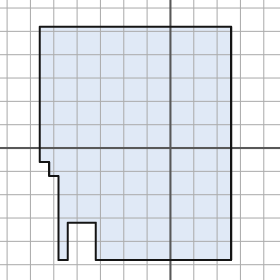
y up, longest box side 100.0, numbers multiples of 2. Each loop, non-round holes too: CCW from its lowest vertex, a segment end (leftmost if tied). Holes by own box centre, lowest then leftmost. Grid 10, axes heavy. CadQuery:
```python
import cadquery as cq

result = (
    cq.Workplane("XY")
    .moveTo(-48.0, -48.0)
    .lineTo(-44.0, -48.0)
    .lineTo(-44.0, -32.0)
    .lineTo(-32.0, -32.0)
    .lineTo(-32.0, -48.0)
    .lineTo(26.0, -48.0)
    .lineTo(26.0, 52.0)
    .lineTo(-56.0, 52.0)
    .lineTo(-56.0, -6.0)
    .lineTo(-52.0, -6.0)
    .lineTo(-52.0, -12.0)
    .lineTo(-48.0, -12.0)
    .close()
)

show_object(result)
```